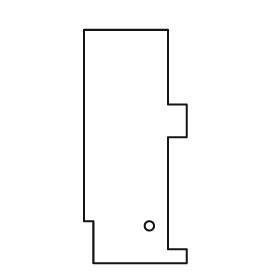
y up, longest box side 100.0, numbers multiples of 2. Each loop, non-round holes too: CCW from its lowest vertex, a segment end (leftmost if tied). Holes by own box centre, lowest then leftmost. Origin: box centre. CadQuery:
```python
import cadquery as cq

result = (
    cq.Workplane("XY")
    .moveTo(-18.0, -50.0)
    .lineTo(22.0, -50.0)
    .lineTo(22.0, -44.0)
    .lineTo(14.0, -44.0)
    .lineTo(14.0, 4.0)
    .lineTo(22.0, 4.0)
    .lineTo(22.0, 18.0)
    .lineTo(14.0, 18.0)
    .lineTo(14.0, 50.0)
    .lineTo(-22.0, 50.0)
    .lineTo(-22.0, -32.0)
    .lineTo(-18.0, -32.0)
    .close()
    .moveTo(6.0, -34.0)
    .circle(2.0)
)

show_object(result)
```